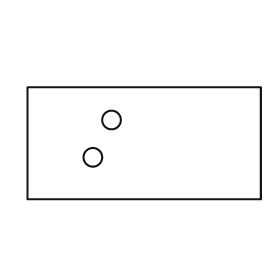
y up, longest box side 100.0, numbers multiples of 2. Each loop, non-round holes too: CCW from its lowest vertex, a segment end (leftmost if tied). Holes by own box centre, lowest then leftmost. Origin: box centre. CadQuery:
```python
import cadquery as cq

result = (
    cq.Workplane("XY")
    .moveTo(-50.0, -24.0)
    .lineTo(50.0, -24.0)
    .lineTo(50.0, 24.0)
    .lineTo(-50.0, 24.0)
    .close()
    .moveTo(-22.0, -6.0)
    .circle(4.0)
    .moveTo(-14.0, 10.0)
    .circle(4.0)
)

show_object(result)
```